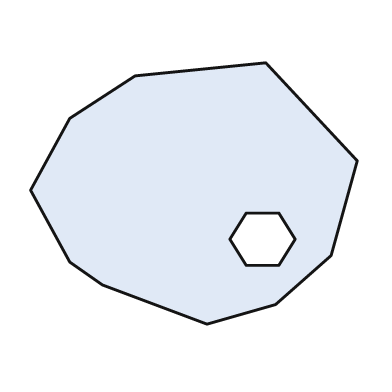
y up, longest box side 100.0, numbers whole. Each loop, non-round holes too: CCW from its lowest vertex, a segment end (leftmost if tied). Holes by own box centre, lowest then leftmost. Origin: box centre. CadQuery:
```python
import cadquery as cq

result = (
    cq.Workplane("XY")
    .moveTo(4.0, -40.0)
    .lineTo(25.0, -34.0)
    .lineTo(42.0, -19.0)
    .lineTo(50.0, 10.0)
    .lineTo(22.0, 40.0)
    .lineTo(-18.0, 36.0)
    .lineTo(-38.0, 23.0)
    .lineTo(-50.0, 1.0)
    .lineTo(-38.0, -21.0)
    .lineTo(-28.0, -28.0)
    .close()
    .moveTo(16.0, -22.0)
    .lineTo(26.0, -22.0)
    .lineTo(31.0, -14.0)
    .lineTo(26.0, -6.0)
    .lineTo(16.0, -6.0)
    .lineTo(11.0, -14.0)
    .close()
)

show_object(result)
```